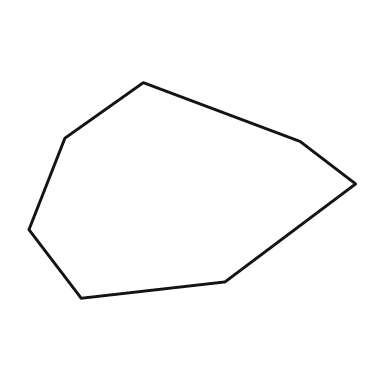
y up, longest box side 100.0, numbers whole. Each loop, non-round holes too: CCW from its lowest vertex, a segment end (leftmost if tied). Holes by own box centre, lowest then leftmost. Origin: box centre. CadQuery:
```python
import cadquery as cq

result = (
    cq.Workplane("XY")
    .moveTo(-34.0, -33.0)
    .lineTo(10.0, -28.0)
    .lineTo(50.0, 2.0)
    .lineTo(33.0, 15.0)
    .lineTo(-15.0, 33.0)
    .lineTo(-39.0, 16.0)
    .lineTo(-50.0, -12.0)
    .close()
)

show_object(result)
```